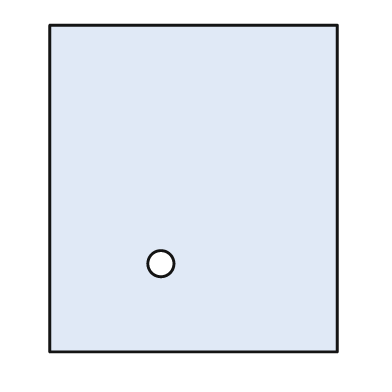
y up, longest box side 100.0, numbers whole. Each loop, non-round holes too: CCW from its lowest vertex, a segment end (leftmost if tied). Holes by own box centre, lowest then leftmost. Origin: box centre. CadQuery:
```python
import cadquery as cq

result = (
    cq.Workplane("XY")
    .moveTo(-44.0, -50.0)
    .lineTo(44.0, -50.0)
    .lineTo(44.0, 50.0)
    .lineTo(-44.0, 50.0)
    .close()
    .moveTo(-10.0, -23.0)
    .circle(4.0)
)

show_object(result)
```